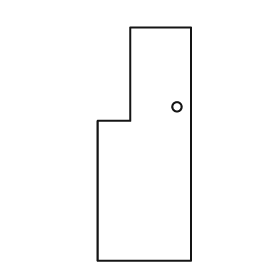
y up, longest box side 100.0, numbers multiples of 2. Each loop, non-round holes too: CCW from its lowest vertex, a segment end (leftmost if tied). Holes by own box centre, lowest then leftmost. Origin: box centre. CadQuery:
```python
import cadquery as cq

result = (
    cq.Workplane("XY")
    .moveTo(-20.0, -50.0)
    .lineTo(20.0, -50.0)
    .lineTo(20.0, 50.0)
    .lineTo(-6.0, 50.0)
    .lineTo(-6.0, 10.0)
    .lineTo(-20.0, 10.0)
    .close()
    .moveTo(14.0, 16.0)
    .circle(2.0)
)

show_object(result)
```